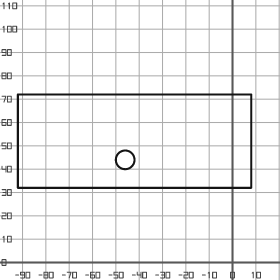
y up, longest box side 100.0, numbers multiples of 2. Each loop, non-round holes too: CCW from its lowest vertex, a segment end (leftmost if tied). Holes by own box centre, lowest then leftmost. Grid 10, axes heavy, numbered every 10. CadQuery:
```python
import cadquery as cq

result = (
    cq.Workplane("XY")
    .moveTo(-92.0, 32.0)
    .lineTo(8.0, 32.0)
    .lineTo(8.0, 72.0)
    .lineTo(-92.0, 72.0)
    .close()
    .moveTo(-46.0, 44.0)
    .circle(4.0)
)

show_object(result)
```